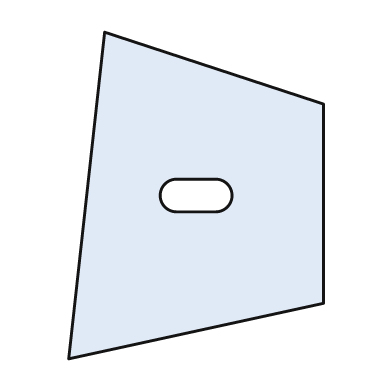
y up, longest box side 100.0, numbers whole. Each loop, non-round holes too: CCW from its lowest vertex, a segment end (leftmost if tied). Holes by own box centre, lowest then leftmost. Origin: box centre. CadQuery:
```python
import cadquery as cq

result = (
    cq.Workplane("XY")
    .moveTo(-39.0, -50.0)
    .lineTo(39.0, -33.0)
    .lineTo(39.0, 28.0)
    .lineTo(-28.0, 50.0)
    .close()
    .moveTo(-6.0, -5.0)
    .lineTo(6.0, -5.0)
    .threePointArc((11.0, 0.0), (6.0, 5.0))
    .lineTo(-6.0, 5.0)
    .threePointArc((-11.0, 0.0), (-6.0, -5.0))
    .close()
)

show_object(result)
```